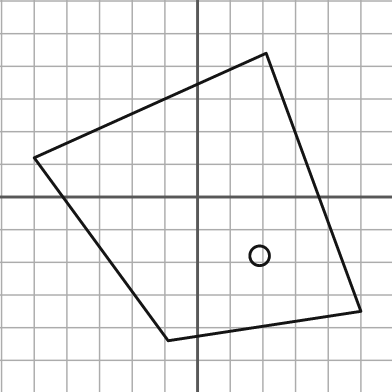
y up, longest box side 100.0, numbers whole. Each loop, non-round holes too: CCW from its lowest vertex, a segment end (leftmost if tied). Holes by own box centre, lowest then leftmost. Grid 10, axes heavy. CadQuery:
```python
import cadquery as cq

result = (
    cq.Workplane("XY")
    .moveTo(-9.0, -44.0)
    .lineTo(50.0, -35.0)
    .lineTo(21.0, 44.0)
    .lineTo(-50.0, 12.0)
    .close()
    .moveTo(19.0, -18.0)
    .circle(3.0)
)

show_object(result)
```